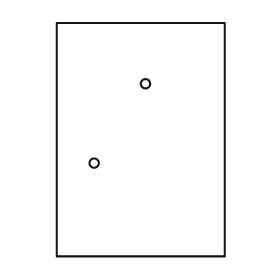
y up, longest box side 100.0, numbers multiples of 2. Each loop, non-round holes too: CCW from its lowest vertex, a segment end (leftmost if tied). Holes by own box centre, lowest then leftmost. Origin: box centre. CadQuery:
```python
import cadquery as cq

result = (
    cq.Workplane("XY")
    .moveTo(-36.0, -50.0)
    .lineTo(36.0, -50.0)
    .lineTo(36.0, 50.0)
    .lineTo(-36.0, 50.0)
    .close()
    .moveTo(-20.0, -10.0)
    .circle(2.0)
    .moveTo(2.0, 24.0)
    .circle(2.0)
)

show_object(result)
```